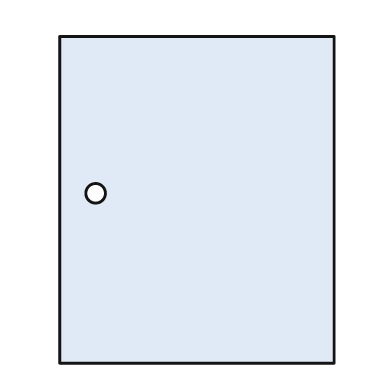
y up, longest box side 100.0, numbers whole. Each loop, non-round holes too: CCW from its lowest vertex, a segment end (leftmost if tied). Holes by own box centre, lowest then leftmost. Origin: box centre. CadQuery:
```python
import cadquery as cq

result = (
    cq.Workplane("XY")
    .moveTo(-42.0, -50.0)
    .lineTo(42.0, -50.0)
    .lineTo(42.0, 50.0)
    .lineTo(-42.0, 50.0)
    .close()
    .moveTo(-31.0, 2.0)
    .circle(3.0)
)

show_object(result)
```